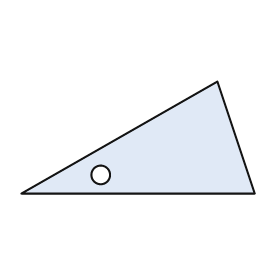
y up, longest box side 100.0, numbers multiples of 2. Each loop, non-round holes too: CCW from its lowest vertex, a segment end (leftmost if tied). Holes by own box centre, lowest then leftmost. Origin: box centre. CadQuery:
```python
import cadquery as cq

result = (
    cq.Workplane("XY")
    .moveTo(-50.0, -24.0)
    .lineTo(50.0, -24.0)
    .lineTo(34.0, 24.0)
    .close()
    .moveTo(-16.0, -16.0)
    .circle(4.0)
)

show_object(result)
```